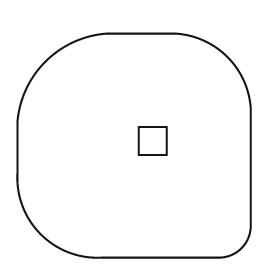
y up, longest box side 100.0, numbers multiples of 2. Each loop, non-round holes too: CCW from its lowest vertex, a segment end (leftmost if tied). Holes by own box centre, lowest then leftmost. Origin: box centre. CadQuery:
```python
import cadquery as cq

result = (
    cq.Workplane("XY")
    .moveTo(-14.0, -48.0)
    .lineTo(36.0, -48.0)
    .threePointArc((46.0, -44.0), (50.0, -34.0))
    .lineTo(50.0, 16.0)
    .threePointArc((40.0, 38.0), (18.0, 48.0))
    .lineTo(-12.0, 48.0)
    .threePointArc((-38.0, 36.0), (-50.0, 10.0))
    .lineTo(-50.0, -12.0)
    .threePointArc((-40.0, -38.0), (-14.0, -48.0))
    .close()
    .moveTo(2.0, -4.0)
    .lineTo(14.0, -4.0)
    .lineTo(14.0, 8.0)
    .lineTo(2.0, 8.0)
    .close()
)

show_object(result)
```